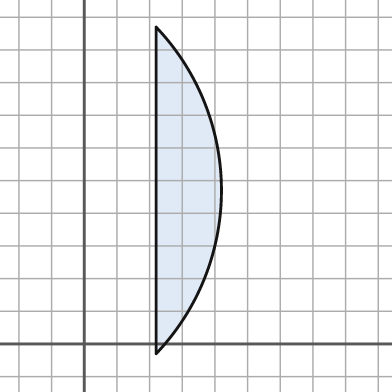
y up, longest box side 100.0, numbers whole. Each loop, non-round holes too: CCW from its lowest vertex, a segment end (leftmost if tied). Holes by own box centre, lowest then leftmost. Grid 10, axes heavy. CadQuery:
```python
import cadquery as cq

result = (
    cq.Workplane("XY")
    .moveTo(22.0, -3.0)
    .threePointArc((42.0, 47.0), (22.0, 97.0))
    .close()
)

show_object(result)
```